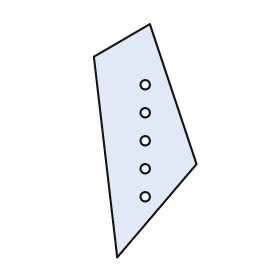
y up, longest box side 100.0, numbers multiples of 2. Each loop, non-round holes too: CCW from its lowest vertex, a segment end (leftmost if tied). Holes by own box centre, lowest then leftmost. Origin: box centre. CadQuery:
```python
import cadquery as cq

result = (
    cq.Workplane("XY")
    .moveTo(-12.0, -50.0)
    .lineTo(22.0, -10.0)
    .lineTo(2.0, 50.0)
    .lineTo(-22.0, 36.0)
    .close()
    .moveTo(0.0, -24.0)
    .circle(2.0)
    .moveTo(0.0, -12.0)
    .circle(2.0)
    .moveTo(0.0, 0.0)
    .circle(2.0)
    .moveTo(0.0, 12.0)
    .circle(2.0)
    .moveTo(0.0, 24.0)
    .circle(2.0)
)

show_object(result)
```